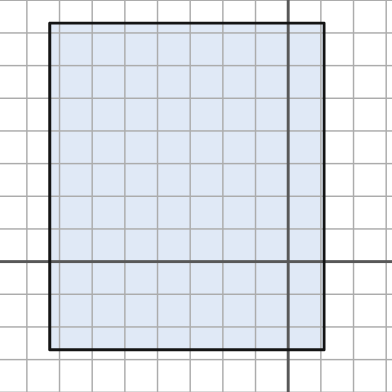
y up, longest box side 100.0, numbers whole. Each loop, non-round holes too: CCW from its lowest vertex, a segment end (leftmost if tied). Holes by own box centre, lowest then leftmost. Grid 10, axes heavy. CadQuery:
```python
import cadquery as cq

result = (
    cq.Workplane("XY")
    .moveTo(-73.0, -27.0)
    .lineTo(11.0, -27.0)
    .lineTo(11.0, 73.0)
    .lineTo(-73.0, 73.0)
    .close()
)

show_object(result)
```